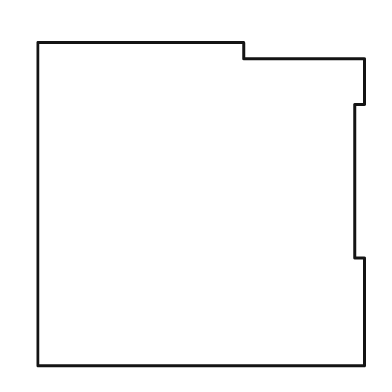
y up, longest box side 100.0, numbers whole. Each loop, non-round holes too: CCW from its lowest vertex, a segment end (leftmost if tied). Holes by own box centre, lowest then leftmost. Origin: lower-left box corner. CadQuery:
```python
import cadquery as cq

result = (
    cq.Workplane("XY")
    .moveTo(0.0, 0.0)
    .lineTo(100.0, 0.0)
    .lineTo(100.0, 33.0)
    .lineTo(97.0, 33.0)
    .lineTo(97.0, 80.0)
    .lineTo(100.0, 80.0)
    .lineTo(100.0, 94.0)
    .lineTo(63.0, 94.0)
    .lineTo(63.0, 99.0)
    .lineTo(0.0, 99.0)
    .close()
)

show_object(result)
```